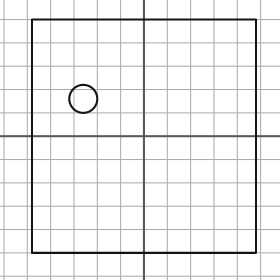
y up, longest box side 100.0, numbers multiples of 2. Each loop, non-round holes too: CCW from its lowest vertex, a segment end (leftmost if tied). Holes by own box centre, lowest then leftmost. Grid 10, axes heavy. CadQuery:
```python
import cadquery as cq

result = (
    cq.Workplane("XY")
    .moveTo(-48.0, -50.0)
    .lineTo(48.0, -50.0)
    .lineTo(48.0, 50.0)
    .lineTo(-48.0, 50.0)
    .close()
    .moveTo(-26.0, 16.0)
    .circle(6.0)
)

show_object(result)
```